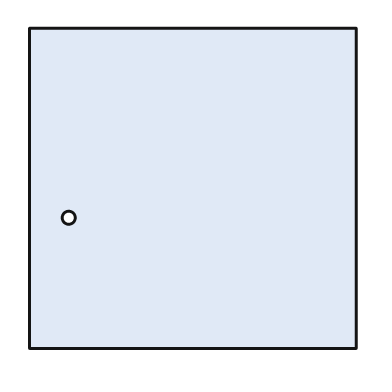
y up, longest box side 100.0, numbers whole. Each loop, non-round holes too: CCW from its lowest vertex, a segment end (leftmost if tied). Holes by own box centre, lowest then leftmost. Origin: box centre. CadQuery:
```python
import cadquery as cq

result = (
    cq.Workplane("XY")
    .moveTo(-50.0, -49.0)
    .lineTo(50.0, -49.0)
    .lineTo(50.0, 49.0)
    .lineTo(-50.0, 49.0)
    .close()
    .moveTo(-38.0, -9.0)
    .circle(2.0)
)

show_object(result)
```